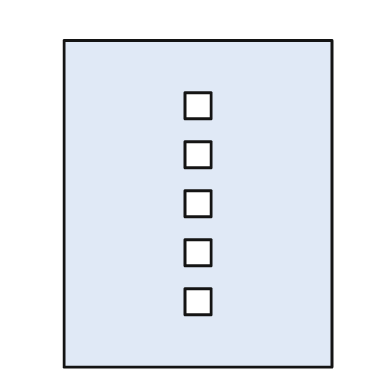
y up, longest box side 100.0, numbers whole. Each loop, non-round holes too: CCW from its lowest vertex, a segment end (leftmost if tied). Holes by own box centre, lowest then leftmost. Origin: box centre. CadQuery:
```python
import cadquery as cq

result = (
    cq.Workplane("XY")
    .moveTo(-41.0, -50.0)
    .lineTo(41.0, -50.0)
    .lineTo(41.0, 50.0)
    .lineTo(-41.0, 50.0)
    .close()
    .moveTo(-4.0, -34.0)
    .lineTo(4.0, -34.0)
    .lineTo(4.0, -26.0)
    .lineTo(-4.0, -26.0)
    .close()
    .moveTo(-4.0, -19.0)
    .lineTo(4.0, -19.0)
    .lineTo(4.0, -11.0)
    .lineTo(-4.0, -11.0)
    .close()
    .moveTo(-4.0, -4.0)
    .lineTo(4.0, -4.0)
    .lineTo(4.0, 4.0)
    .lineTo(-4.0, 4.0)
    .close()
    .moveTo(-4.0, 11.0)
    .lineTo(4.0, 11.0)
    .lineTo(4.0, 19.0)
    .lineTo(-4.0, 19.0)
    .close()
    .moveTo(-4.0, 26.0)
    .lineTo(4.0, 26.0)
    .lineTo(4.0, 34.0)
    .lineTo(-4.0, 34.0)
    .close()
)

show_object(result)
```